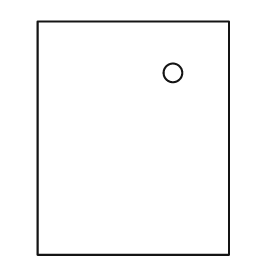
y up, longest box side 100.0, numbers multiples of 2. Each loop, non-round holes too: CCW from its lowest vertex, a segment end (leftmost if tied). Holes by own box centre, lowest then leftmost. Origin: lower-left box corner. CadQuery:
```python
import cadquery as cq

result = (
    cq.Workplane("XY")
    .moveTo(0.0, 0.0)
    .lineTo(82.0, 0.0)
    .lineTo(82.0, 100.0)
    .lineTo(0.0, 100.0)
    .close()
    .moveTo(58.0, 78.0)
    .circle(4.0)
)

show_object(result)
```